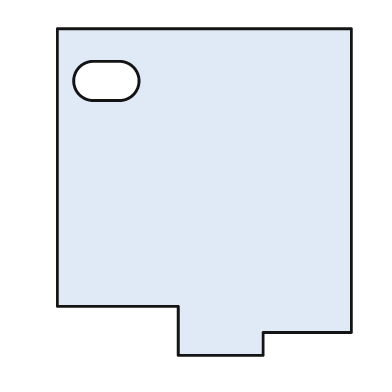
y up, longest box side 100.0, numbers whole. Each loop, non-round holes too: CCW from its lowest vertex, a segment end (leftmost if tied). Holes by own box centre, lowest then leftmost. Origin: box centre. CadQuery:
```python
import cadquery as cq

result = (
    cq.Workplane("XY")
    .moveTo(-8.0, -50.0)
    .lineTo(18.0, -50.0)
    .lineTo(18.0, -43.0)
    .lineTo(45.0, -43.0)
    .lineTo(45.0, 50.0)
    .lineTo(-45.0, 50.0)
    .lineTo(-45.0, -35.0)
    .lineTo(-8.0, -35.0)
    .close()
    .moveTo(-34.0, 28.0)
    .lineTo(-26.0, 28.0)
    .threePointArc((-20.0, 34.0), (-26.0, 40.0))
    .lineTo(-34.0, 40.0)
    .threePointArc((-40.0, 34.0), (-34.0, 28.0))
    .close()
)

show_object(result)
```